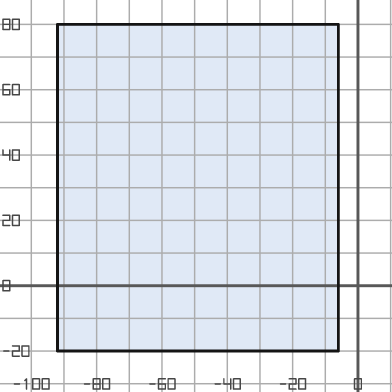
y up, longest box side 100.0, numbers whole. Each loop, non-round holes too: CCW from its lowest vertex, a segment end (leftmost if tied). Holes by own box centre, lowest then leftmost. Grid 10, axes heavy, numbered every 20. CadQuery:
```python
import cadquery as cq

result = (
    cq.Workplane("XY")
    .moveTo(-92.0, -20.0)
    .lineTo(-6.0, -20.0)
    .lineTo(-6.0, 80.0)
    .lineTo(-92.0, 80.0)
    .close()
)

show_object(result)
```